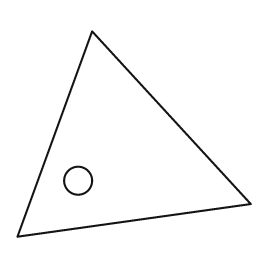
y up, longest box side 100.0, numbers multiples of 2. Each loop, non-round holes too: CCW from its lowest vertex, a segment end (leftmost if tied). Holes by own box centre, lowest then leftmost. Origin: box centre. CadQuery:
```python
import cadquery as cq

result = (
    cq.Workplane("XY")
    .moveTo(-50.0, -44.0)
    .lineTo(50.0, -30.0)
    .lineTo(-18.0, 44.0)
    .close()
    .moveTo(-24.0, -20.0)
    .circle(6.0)
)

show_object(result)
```